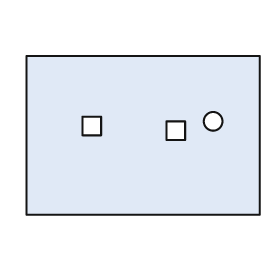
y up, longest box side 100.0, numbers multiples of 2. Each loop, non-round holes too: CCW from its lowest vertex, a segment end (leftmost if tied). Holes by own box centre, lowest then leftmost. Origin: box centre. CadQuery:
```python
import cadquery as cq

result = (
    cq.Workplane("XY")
    .moveTo(-50.0, -34.0)
    .lineTo(50.0, -34.0)
    .lineTo(50.0, 34.0)
    .lineTo(-50.0, 34.0)
    .close()
    .moveTo(10.0, -2.0)
    .lineTo(18.0, -2.0)
    .lineTo(18.0, 6.0)
    .lineTo(10.0, 6.0)
    .close()
    .moveTo(-26.0, 0.0)
    .lineTo(-18.0, 0.0)
    .lineTo(-18.0, 8.0)
    .lineTo(-26.0, 8.0)
    .close()
    .moveTo(30.0, 6.0)
    .circle(4.0)
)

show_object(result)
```